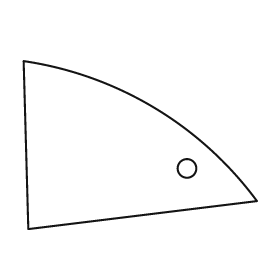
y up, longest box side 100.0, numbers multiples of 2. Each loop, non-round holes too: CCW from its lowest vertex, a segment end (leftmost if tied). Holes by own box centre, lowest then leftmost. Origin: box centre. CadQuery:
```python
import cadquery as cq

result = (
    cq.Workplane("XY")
    .moveTo(-48.0, -36.0)
    .lineTo(50.0, -24.0)
    .threePointArc((6.0, 16.0), (-50.0, 36.0))
    .close()
    .moveTo(20.0, -10.0)
    .circle(4.0)
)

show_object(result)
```